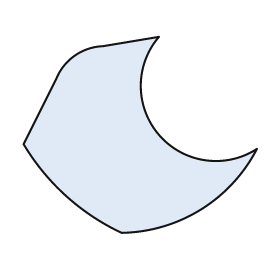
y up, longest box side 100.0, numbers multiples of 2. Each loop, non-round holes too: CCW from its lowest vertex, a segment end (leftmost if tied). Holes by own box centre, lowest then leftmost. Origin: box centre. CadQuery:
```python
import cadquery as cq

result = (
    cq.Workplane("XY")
    .moveTo(-8.0, -42.0)
    .threePointArc((26.0, -32.0), (50.0, -6.0))
    .threePointArc((8.0, 0.0), (8.0, 42.0))
    .lineTo(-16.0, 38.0)
    .threePointArc((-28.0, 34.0), (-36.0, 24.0))
    .lineTo(-50.0, -4.0)
    .threePointArc((-32.0, -26.0), (-8.0, -42.0))
    .close()
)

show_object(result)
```